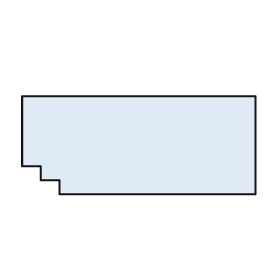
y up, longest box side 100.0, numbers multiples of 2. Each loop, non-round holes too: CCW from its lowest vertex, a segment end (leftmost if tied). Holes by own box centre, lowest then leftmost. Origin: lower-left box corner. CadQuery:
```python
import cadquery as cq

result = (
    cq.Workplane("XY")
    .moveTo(16.0, 0.0)
    .lineTo(100.0, 0.0)
    .lineTo(100.0, 42.0)
    .lineTo(0.0, 42.0)
    .lineTo(0.0, 12.0)
    .lineTo(8.0, 12.0)
    .lineTo(8.0, 6.0)
    .lineTo(16.0, 6.0)
    .close()
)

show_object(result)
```